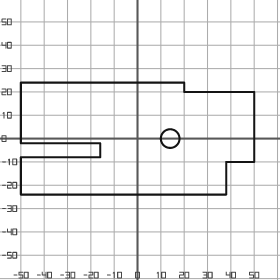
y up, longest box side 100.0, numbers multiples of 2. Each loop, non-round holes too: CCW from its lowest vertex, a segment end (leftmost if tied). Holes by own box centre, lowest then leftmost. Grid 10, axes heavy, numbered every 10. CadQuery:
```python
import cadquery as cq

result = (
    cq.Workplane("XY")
    .moveTo(-50.0, -24.0)
    .lineTo(38.0, -24.0)
    .lineTo(38.0, -10.0)
    .lineTo(50.0, -10.0)
    .lineTo(50.0, 20.0)
    .lineTo(20.0, 20.0)
    .lineTo(20.0, 24.0)
    .lineTo(-50.0, 24.0)
    .lineTo(-50.0, -2.0)
    .lineTo(-16.0, -2.0)
    .lineTo(-16.0, -8.0)
    .lineTo(-50.0, -8.0)
    .close()
    .moveTo(14.0, 0.0)
    .circle(4.0)
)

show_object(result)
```